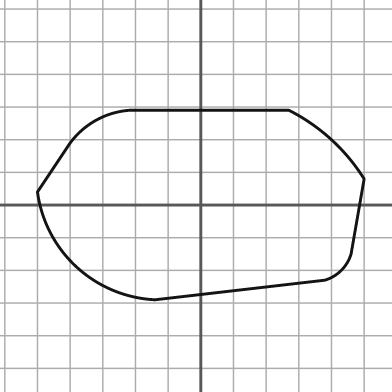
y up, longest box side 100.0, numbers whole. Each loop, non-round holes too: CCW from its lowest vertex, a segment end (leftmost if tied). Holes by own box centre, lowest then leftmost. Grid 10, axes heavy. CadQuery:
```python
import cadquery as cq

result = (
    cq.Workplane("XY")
    .moveTo(-14.0, -29.0)
    .lineTo(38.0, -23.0)
    .threePointArc((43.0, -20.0), (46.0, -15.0))
    .lineTo(50.0, 8.0)
    .threePointArc((40.0, 20.0), (27.0, 29.0))
    .lineTo(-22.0, 29.0)
    .threePointArc((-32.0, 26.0), (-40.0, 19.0))
    .lineTo(-50.0, 4.0)
    .threePointArc((-38.0, -19.0), (-14.0, -29.0))
    .close()
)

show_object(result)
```